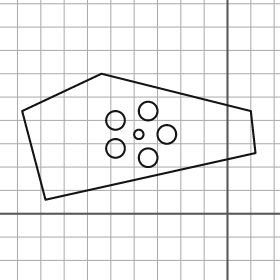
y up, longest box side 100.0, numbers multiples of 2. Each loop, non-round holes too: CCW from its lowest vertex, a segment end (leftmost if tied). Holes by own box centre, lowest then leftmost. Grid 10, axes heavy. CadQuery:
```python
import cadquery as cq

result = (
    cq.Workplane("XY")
    .moveTo(-78.0, 6.0)
    .lineTo(12.0, 26.0)
    .lineTo(10.0, 44.0)
    .lineTo(-54.0, 60.0)
    .lineTo(-88.0, 44.0)
    .close()
    .moveTo(-34.0, 24.0)
    .circle(4.0)
    .moveTo(-48.0, 28.0)
    .circle(4.0)
    .moveTo(-38.0, 34.0)
    .circle(2.0)
    .moveTo(-26.0, 34.0)
    .circle(4.0)
    .moveTo(-48.0, 40.0)
    .circle(4.0)
    .moveTo(-34.0, 44.0)
    .circle(4.0)
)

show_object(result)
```